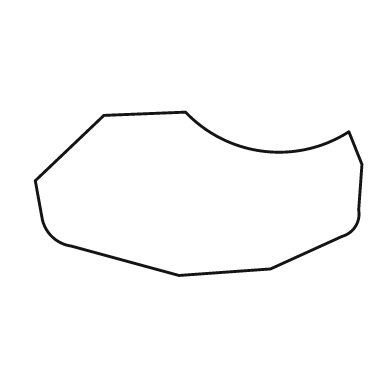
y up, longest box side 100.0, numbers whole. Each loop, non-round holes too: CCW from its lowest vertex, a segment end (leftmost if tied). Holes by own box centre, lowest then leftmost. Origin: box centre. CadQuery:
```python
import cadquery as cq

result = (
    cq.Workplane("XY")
    .moveTo(-6.0, -25.0)
    .lineTo(22.0, -23.0)
    .lineTo(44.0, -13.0)
    .threePointArc((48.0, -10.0), (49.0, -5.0))
    .lineTo(50.0, 9.0)
    .lineTo(46.0, 19.0)
    .threePointArc((20.0, 13.0), (-4.0, 25.0))
    .lineTo(-29.0, 24.0)
    .lineTo(-50.0, 4.0)
    .lineTo(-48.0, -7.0)
    .threePointArc((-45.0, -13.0), (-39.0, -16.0))
    .close()
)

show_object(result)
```